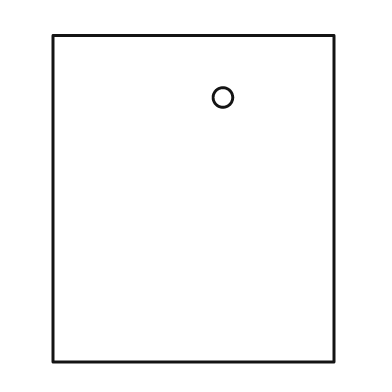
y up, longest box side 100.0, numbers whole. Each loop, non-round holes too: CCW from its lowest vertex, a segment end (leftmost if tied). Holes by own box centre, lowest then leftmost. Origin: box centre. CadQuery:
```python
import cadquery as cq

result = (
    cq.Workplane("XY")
    .moveTo(-43.0, -50.0)
    .lineTo(43.0, -50.0)
    .lineTo(43.0, 50.0)
    .lineTo(-43.0, 50.0)
    .close()
    .moveTo(9.0, 31.0)
    .circle(3.0)
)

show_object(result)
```